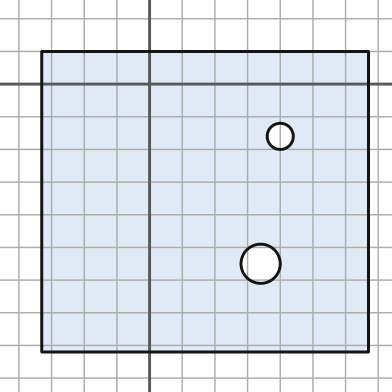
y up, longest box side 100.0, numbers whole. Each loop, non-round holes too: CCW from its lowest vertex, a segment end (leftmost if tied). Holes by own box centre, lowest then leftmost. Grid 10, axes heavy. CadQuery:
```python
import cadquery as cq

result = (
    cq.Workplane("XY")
    .moveTo(-33.0, -82.0)
    .lineTo(67.0, -82.0)
    .lineTo(67.0, 10.0)
    .lineTo(-33.0, 10.0)
    .close()
    .moveTo(34.0, -55.0)
    .circle(6.0)
    .moveTo(40.0, -16.0)
    .circle(4.0)
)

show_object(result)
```